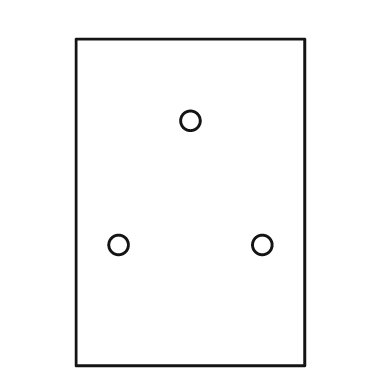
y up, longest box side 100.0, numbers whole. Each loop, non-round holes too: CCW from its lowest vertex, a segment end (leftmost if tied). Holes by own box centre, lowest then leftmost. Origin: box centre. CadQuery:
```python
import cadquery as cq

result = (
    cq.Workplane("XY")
    .moveTo(-35.0, -50.0)
    .lineTo(35.0, -50.0)
    .lineTo(35.0, 50.0)
    .lineTo(-35.0, 50.0)
    .close()
    .moveTo(-22.0, -13.0)
    .circle(3.0)
    .moveTo(22.0, -13.0)
    .circle(3.0)
    .moveTo(0.0, 25.0)
    .circle(3.0)
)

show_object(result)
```